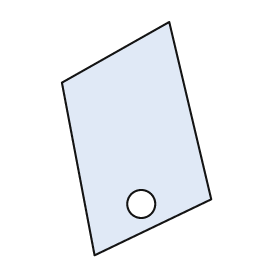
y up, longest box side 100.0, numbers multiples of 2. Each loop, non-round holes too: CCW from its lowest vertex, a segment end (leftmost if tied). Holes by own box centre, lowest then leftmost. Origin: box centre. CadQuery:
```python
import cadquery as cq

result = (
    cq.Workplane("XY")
    .moveTo(-18.0, -50.0)
    .lineTo(32.0, -26.0)
    .lineTo(14.0, 50.0)
    .lineTo(-32.0, 24.0)
    .close()
    .moveTo(2.0, -28.0)
    .circle(6.0)
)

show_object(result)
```